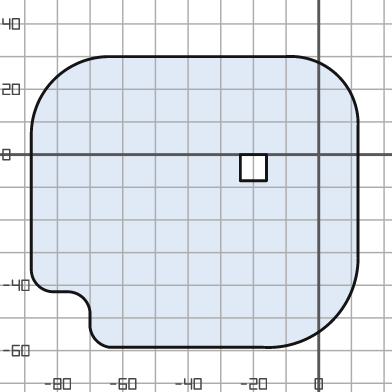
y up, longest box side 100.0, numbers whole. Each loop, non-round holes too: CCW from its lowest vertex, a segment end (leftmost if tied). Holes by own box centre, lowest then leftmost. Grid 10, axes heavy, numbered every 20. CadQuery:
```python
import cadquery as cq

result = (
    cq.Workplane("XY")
    .moveTo(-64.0, -59.0)
    .lineTo(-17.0, -59.0)
    .threePointArc((4.0, -51.0), (12.0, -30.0))
    .lineTo(12.0, 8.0)
    .threePointArc((6.0, 24.0), (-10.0, 30.0))
    .lineTo(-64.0, 30.0)
    .threePointArc((-81.0, 23.0), (-88.0, 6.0))
    .lineTo(-88.0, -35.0)
    .threePointArc((-86.0, -40.0), (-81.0, -42.0))
    .lineTo(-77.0, -42.0)
    .threePointArc((-72.0, -44.0), (-70.0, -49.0))
    .lineTo(-70.0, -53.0)
    .threePointArc((-68.0, -57.0), (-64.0, -59.0))
    .close()
    .moveTo(-24.0, -8.0)
    .lineTo(-16.0, -8.0)
    .lineTo(-16.0, 0.0)
    .lineTo(-24.0, 0.0)
    .close()
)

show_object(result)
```